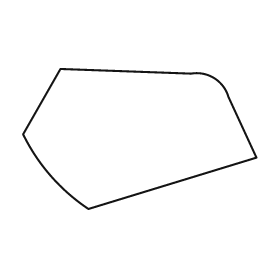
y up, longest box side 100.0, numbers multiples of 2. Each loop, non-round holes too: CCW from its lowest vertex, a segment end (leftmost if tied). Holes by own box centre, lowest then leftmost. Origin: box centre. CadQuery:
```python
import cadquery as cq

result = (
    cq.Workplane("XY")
    .moveTo(-22.0, -30.0)
    .lineTo(50.0, -8.0)
    .lineTo(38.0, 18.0)
    .threePointArc((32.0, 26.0), (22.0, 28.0))
    .lineTo(-34.0, 30.0)
    .lineTo(-50.0, 2.0)
    .threePointArc((-38.0, -16.0), (-22.0, -30.0))
    .close()
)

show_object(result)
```